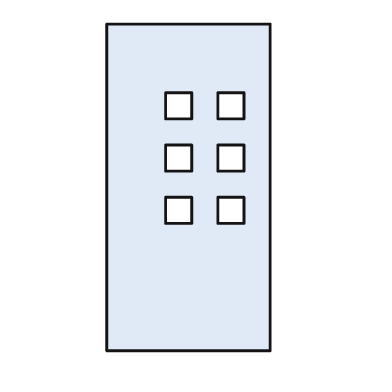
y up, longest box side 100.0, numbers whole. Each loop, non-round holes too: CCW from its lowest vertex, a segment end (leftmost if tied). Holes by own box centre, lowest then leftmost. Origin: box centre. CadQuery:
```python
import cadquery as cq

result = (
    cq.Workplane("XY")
    .moveTo(-25.0, -50.0)
    .lineTo(25.0, -50.0)
    .lineTo(25.0, 50.0)
    .lineTo(-25.0, 50.0)
    .close()
    .moveTo(-7.0, -11.0)
    .lineTo(1.0, -11.0)
    .lineTo(1.0, -3.0)
    .lineTo(-7.0, -3.0)
    .close()
    .moveTo(9.0, -11.0)
    .lineTo(17.0, -11.0)
    .lineTo(17.0, -3.0)
    .lineTo(9.0, -3.0)
    .close()
    .moveTo(-7.0, 5.0)
    .lineTo(1.0, 5.0)
    .lineTo(1.0, 13.0)
    .lineTo(-7.0, 13.0)
    .close()
    .moveTo(9.0, 5.0)
    .lineTo(17.0, 5.0)
    .lineTo(17.0, 13.0)
    .lineTo(9.0, 13.0)
    .close()
    .moveTo(-7.0, 21.0)
    .lineTo(1.0, 21.0)
    .lineTo(1.0, 29.0)
    .lineTo(-7.0, 29.0)
    .close()
    .moveTo(9.0, 21.0)
    .lineTo(17.0, 21.0)
    .lineTo(17.0, 29.0)
    .lineTo(9.0, 29.0)
    .close()
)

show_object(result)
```